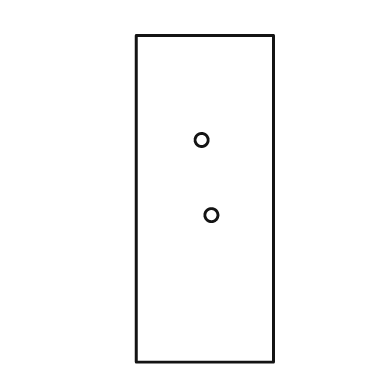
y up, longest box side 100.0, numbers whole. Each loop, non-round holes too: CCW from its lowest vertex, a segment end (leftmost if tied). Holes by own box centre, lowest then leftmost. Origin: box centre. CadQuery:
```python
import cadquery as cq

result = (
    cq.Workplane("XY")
    .moveTo(-21.0, -50.0)
    .lineTo(21.0, -50.0)
    .lineTo(21.0, 50.0)
    .lineTo(-21.0, 50.0)
    .close()
    .moveTo(2.0, -5.0)
    .circle(2.0)
    .moveTo(-1.0, 18.0)
    .circle(2.0)
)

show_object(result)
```